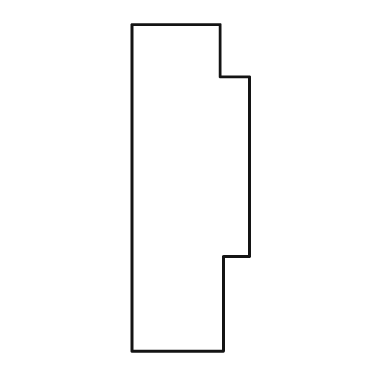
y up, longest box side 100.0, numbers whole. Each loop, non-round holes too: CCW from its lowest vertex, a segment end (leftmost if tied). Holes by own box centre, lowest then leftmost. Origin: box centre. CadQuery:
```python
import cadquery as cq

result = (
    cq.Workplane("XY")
    .moveTo(-18.0, -50.0)
    .lineTo(10.0, -50.0)
    .lineTo(10.0, -21.0)
    .lineTo(18.0, -21.0)
    .lineTo(18.0, 34.0)
    .lineTo(9.0, 34.0)
    .lineTo(9.0, 50.0)
    .lineTo(-18.0, 50.0)
    .close()
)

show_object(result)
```